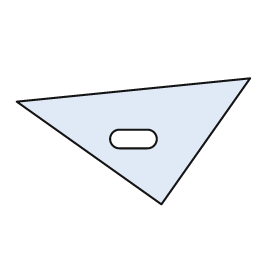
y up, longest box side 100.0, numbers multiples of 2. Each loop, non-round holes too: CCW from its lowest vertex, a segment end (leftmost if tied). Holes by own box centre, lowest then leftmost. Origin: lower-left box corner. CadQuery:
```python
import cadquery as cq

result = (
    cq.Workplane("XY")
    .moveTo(62.0, 0.0)
    .lineTo(100.0, 54.0)
    .lineTo(0.0, 44.0)
    .close()
    .moveTo(44.0, 24.0)
    .lineTo(56.0, 24.0)
    .threePointArc((60.0, 28.0), (56.0, 32.0))
    .lineTo(44.0, 32.0)
    .threePointArc((40.0, 28.0), (44.0, 24.0))
    .close()
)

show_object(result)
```